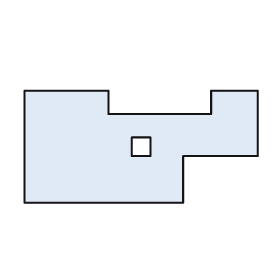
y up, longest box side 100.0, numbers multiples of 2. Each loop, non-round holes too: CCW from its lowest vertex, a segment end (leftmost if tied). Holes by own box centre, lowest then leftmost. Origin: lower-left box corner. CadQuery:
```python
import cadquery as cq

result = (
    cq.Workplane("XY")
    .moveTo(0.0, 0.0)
    .lineTo(68.0, 0.0)
    .lineTo(68.0, 20.0)
    .lineTo(100.0, 20.0)
    .lineTo(100.0, 48.0)
    .lineTo(80.0, 48.0)
    .lineTo(80.0, 38.0)
    .lineTo(36.0, 38.0)
    .lineTo(36.0, 48.0)
    .lineTo(0.0, 48.0)
    .close()
    .moveTo(46.0, 20.0)
    .lineTo(54.0, 20.0)
    .lineTo(54.0, 28.0)
    .lineTo(46.0, 28.0)
    .close()
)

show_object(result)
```